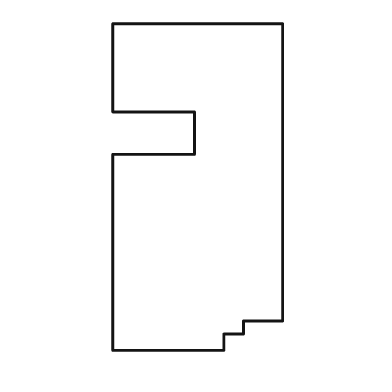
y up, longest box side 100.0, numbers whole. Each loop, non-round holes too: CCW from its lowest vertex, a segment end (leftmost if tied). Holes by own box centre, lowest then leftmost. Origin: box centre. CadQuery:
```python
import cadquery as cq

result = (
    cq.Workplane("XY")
    .moveTo(-26.0, -50.0)
    .lineTo(8.0, -50.0)
    .lineTo(8.0, -45.0)
    .lineTo(14.0, -45.0)
    .lineTo(14.0, -41.0)
    .lineTo(26.0, -41.0)
    .lineTo(26.0, 50.0)
    .lineTo(-26.0, 50.0)
    .lineTo(-26.0, 23.0)
    .lineTo(-1.0, 23.0)
    .lineTo(-1.0, 10.0)
    .lineTo(-26.0, 10.0)
    .close()
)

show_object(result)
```